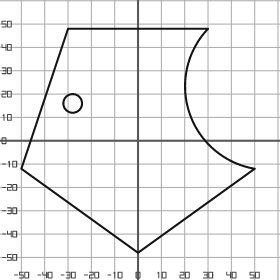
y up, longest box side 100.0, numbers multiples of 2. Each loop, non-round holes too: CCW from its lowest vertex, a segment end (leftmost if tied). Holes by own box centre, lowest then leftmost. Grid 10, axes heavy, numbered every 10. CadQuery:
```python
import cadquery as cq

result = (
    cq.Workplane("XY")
    .moveTo(0.0, -48.0)
    .lineTo(50.0, -12.0)
    .threePointArc((22.0, 12.0), (30.0, 48.0))
    .lineTo(-30.0, 48.0)
    .lineTo(-50.0, -12.0)
    .close()
    .moveTo(-28.0, 16.0)
    .circle(4.0)
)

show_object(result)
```